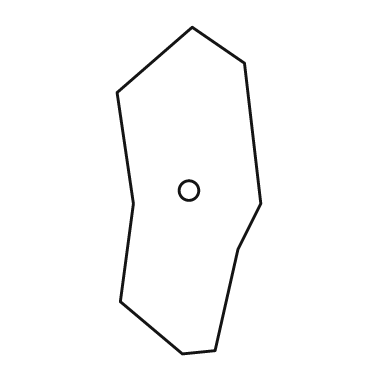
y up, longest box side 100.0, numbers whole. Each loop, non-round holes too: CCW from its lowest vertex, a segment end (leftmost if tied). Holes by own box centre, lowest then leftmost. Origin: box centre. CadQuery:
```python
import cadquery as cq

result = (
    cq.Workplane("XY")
    .moveTo(-2.0, -50.0)
    .lineTo(8.0, -49.0)
    .lineTo(15.0, -18.0)
    .lineTo(22.0, -4.0)
    .lineTo(17.0, 39.0)
    .lineTo(1.0, 50.0)
    .lineTo(-22.0, 30.0)
    .lineTo(-17.0, -4.0)
    .lineTo(-21.0, -34.0)
    .close()
    .moveTo(0.0, 0.0)
    .circle(3.0)
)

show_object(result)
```